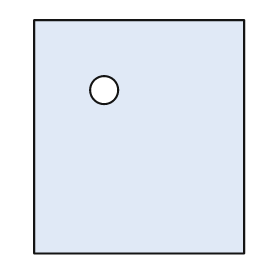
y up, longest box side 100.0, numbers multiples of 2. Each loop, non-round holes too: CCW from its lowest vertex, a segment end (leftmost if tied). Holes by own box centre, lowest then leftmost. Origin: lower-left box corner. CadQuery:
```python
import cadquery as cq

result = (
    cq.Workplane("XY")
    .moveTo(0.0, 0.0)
    .lineTo(90.0, 0.0)
    .lineTo(90.0, 100.0)
    .lineTo(0.0, 100.0)
    .close()
    .moveTo(30.0, 70.0)
    .circle(6.0)
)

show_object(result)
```